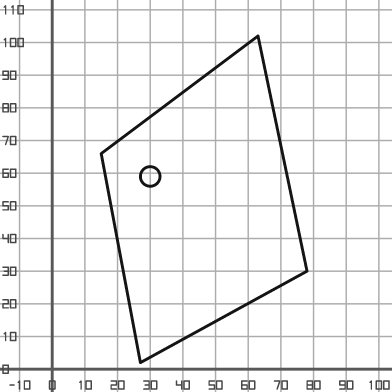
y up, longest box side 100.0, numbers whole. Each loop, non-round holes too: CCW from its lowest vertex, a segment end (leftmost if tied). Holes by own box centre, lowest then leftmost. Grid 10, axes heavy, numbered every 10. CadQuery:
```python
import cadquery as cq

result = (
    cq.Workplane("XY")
    .moveTo(27.0, 2.0)
    .lineTo(78.0, 30.0)
    .lineTo(63.0, 102.0)
    .lineTo(15.0, 66.0)
    .close()
    .moveTo(30.0, 59.0)
    .circle(3.0)
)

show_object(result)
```